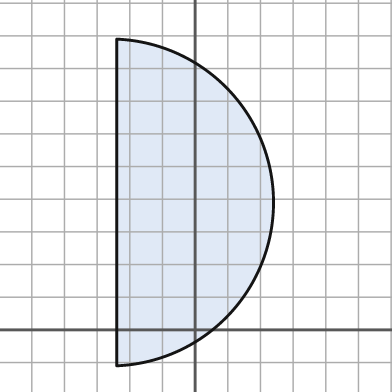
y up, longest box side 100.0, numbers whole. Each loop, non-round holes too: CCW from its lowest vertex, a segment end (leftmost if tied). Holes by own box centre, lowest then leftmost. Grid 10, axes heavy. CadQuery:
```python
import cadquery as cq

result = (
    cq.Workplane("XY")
    .moveTo(-24.0, -11.0)
    .threePointArc((24.0, 39.0), (-24.0, 89.0))
    .close()
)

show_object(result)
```